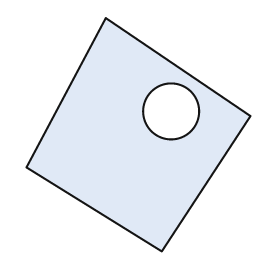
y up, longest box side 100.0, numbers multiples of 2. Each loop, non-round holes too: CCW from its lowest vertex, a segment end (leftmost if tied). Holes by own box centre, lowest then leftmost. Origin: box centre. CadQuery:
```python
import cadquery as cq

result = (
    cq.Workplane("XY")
    .moveTo(10.0, -50.0)
    .lineTo(48.0, 8.0)
    .lineTo(-14.0, 50.0)
    .lineTo(-48.0, -14.0)
    .close()
    .moveTo(14.0, 10.0)
    .circle(12.0)
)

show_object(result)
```